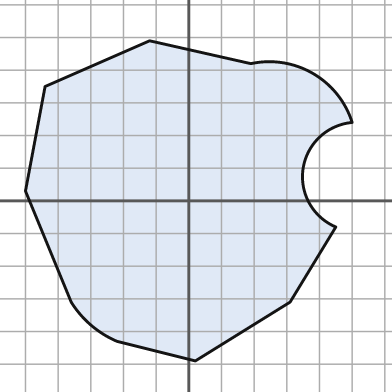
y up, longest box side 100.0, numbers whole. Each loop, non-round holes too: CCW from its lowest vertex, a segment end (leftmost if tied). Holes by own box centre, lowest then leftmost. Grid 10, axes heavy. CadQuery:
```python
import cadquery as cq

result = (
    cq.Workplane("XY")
    .moveTo(2.0, -49.0)
    .lineTo(31.0, -31.0)
    .lineTo(45.0, -8.0)
    .threePointArc((35.0, 10.0), (50.0, 24.0))
    .threePointArc((38.0, 39.0), (19.0, 42.0))
    .lineTo(-12.0, 49.0)
    .lineTo(-44.0, 35.0)
    .lineTo(-50.0, 3.0)
    .lineTo(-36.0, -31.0)
    .threePointArc((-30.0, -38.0), (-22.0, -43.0))
    .close()
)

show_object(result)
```